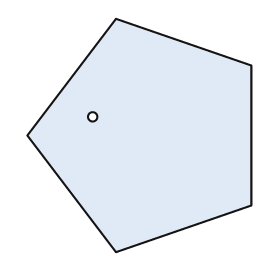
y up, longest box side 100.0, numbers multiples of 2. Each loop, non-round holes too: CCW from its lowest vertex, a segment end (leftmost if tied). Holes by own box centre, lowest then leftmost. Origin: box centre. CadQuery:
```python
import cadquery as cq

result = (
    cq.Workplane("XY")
    .moveTo(-10.0, -50.0)
    .lineTo(48.0, -30.0)
    .lineTo(48.0, 30.0)
    .lineTo(-10.0, 50.0)
    .lineTo(-48.0, 0.0)
    .close()
    .moveTo(-20.0, 8.0)
    .circle(2.0)
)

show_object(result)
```